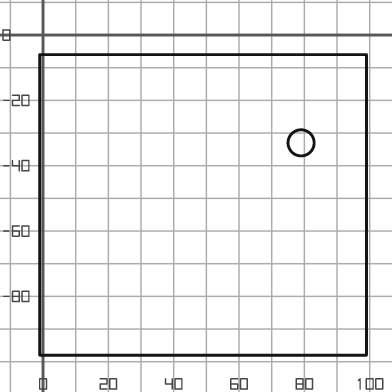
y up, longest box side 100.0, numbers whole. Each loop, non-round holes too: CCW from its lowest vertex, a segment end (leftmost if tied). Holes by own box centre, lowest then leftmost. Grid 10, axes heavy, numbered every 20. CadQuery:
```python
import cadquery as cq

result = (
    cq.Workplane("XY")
    .moveTo(-1.0, -98.0)
    .lineTo(99.0, -98.0)
    .lineTo(99.0, -6.0)
    .lineTo(-1.0, -6.0)
    .close()
    .moveTo(79.0, -33.0)
    .circle(4.0)
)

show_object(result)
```